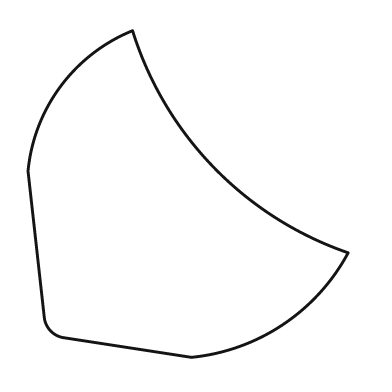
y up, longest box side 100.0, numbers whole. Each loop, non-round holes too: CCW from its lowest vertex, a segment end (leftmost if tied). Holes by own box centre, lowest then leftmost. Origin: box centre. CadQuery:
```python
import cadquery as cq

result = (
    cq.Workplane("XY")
    .moveTo(1.0, -50.0)
    .threePointArc((29.0, -40.0), (49.0, -18.0))
    .threePointArc((8.0, 8.0), (-17.0, 50.0))
    .threePointArc((-39.0, 33.0), (-49.0, 7.0))
    .lineTo(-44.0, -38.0)
    .threePointArc((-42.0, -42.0), (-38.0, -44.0))
    .close()
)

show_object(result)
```